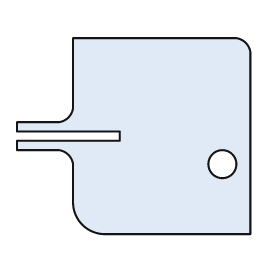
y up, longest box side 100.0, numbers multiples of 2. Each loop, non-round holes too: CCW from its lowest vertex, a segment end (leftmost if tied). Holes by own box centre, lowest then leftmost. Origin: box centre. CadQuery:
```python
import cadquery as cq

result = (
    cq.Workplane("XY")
    .moveTo(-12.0, -42.0)
    .lineTo(50.0, -42.0)
    .lineTo(50.0, 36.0)
    .threePointArc((48.0, 40.0), (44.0, 42.0))
    .lineTo(-26.0, 42.0)
    .lineTo(-26.0, 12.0)
    .threePointArc((-28.0, 8.0), (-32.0, 6.0))
    .lineTo(-50.0, 6.0)
    .lineTo(-50.0, 2.0)
    .lineTo(-6.0, 2.0)
    .lineTo(-6.0, -2.0)
    .lineTo(-50.0, -2.0)
    .lineTo(-50.0, -6.0)
    .lineTo(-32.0, -6.0)
    .threePointArc((-28.0, -8.0), (-26.0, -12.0))
    .lineTo(-26.0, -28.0)
    .threePointArc((-22.0, -38.0), (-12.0, -42.0))
    .close()
    .moveTo(38.0, -12.0)
    .circle(6.0)
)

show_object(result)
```